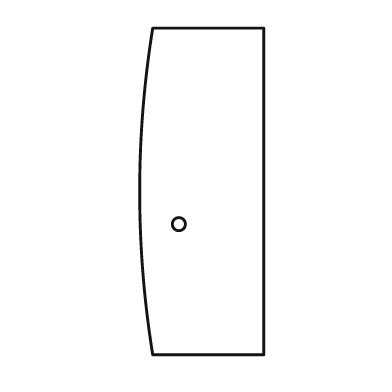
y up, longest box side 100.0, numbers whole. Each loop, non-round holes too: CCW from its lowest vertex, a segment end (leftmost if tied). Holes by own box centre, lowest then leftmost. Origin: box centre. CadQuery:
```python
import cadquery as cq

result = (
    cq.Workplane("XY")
    .moveTo(-15.0, -50.0)
    .lineTo(19.0, -50.0)
    .lineTo(19.0, 50.0)
    .lineTo(-15.0, 50.0)
    .threePointArc((-19.0, 0.0), (-15.0, -50.0))
    .close()
    .moveTo(-7.0, -10.0)
    .circle(2.0)
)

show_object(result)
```